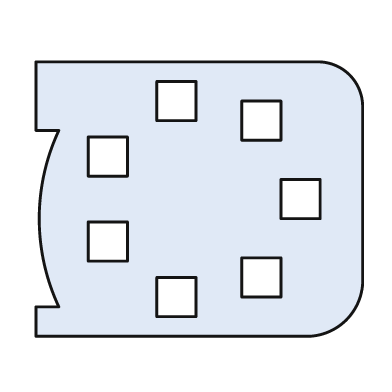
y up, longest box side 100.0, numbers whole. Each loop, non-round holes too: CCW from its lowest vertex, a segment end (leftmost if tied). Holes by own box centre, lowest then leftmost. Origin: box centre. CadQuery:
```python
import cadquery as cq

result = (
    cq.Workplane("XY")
    .moveTo(-50.0, -42.0)
    .lineTo(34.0, -42.0)
    .threePointArc((45.0, -37.0), (50.0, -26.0))
    .lineTo(50.0, 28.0)
    .threePointArc((46.0, 38.0), (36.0, 42.0))
    .lineTo(-50.0, 42.0)
    .lineTo(-50.0, 21.0)
    .lineTo(-43.0, 21.0)
    .threePointArc((-49.0, -6.0), (-43.0, -33.0))
    .lineTo(-50.0, -33.0)
    .close()
    .moveTo(-13.0, -36.0)
    .lineTo(-1.0, -36.0)
    .lineTo(-1.0, -24.0)
    .lineTo(-13.0, -24.0)
    .close()
    .moveTo(13.0, -30.0)
    .lineTo(25.0, -30.0)
    .lineTo(25.0, -18.0)
    .lineTo(13.0, -18.0)
    .close()
    .moveTo(-34.0, -19.0)
    .lineTo(-22.0, -19.0)
    .lineTo(-22.0, -7.0)
    .lineTo(-34.0, -7.0)
    .close()
    .moveTo(25.0, -6.0)
    .lineTo(37.0, -6.0)
    .lineTo(37.0, 6.0)
    .lineTo(25.0, 6.0)
    .close()
    .moveTo(-34.0, 7.0)
    .lineTo(-22.0, 7.0)
    .lineTo(-22.0, 19.0)
    .lineTo(-34.0, 19.0)
    .close()
    .moveTo(13.0, 18.0)
    .lineTo(25.0, 18.0)
    .lineTo(25.0, 30.0)
    .lineTo(13.0, 30.0)
    .close()
    .moveTo(-13.0, 24.0)
    .lineTo(-1.0, 24.0)
    .lineTo(-1.0, 36.0)
    .lineTo(-13.0, 36.0)
    .close()
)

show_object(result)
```